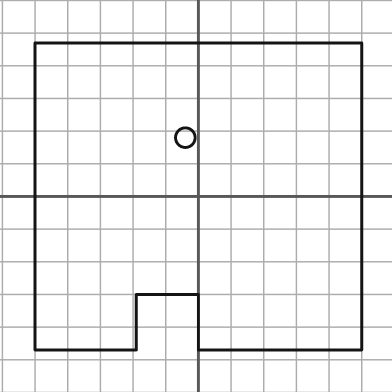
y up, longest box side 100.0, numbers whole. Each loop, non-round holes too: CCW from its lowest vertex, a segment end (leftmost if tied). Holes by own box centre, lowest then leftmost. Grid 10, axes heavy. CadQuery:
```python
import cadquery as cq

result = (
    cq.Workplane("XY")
    .moveTo(-50.0, -47.0)
    .lineTo(-19.0, -47.0)
    .lineTo(-19.0, -30.0)
    .lineTo(0.0, -30.0)
    .lineTo(0.0, -47.0)
    .lineTo(50.0, -47.0)
    .lineTo(50.0, 47.0)
    .lineTo(-50.0, 47.0)
    .close()
    .moveTo(-4.0, 18.0)
    .circle(3.0)
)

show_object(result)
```